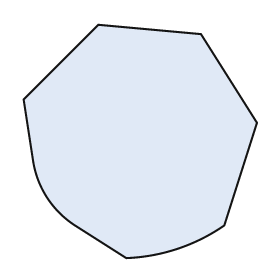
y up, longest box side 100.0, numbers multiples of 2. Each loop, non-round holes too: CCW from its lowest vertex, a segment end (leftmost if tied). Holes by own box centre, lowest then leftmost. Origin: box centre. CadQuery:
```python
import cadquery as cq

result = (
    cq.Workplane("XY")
    .moveTo(-6.0, -50.0)
    .threePointArc((16.0, -46.0), (36.0, -36.0))
    .lineTo(50.0, 8.0)
    .lineTo(26.0, 46.0)
    .lineTo(-18.0, 50.0)
    .lineTo(-50.0, 18.0)
    .lineTo(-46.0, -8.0)
    .threePointArc((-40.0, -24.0), (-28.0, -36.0))
    .close()
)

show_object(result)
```